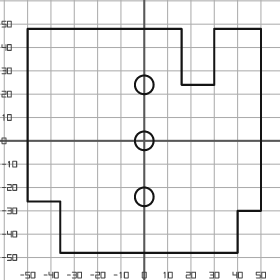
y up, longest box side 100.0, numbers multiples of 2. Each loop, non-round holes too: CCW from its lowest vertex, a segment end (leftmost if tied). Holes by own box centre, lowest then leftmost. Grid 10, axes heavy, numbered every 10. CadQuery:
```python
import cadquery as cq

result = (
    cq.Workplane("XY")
    .moveTo(-36.0, -48.0)
    .lineTo(40.0, -48.0)
    .lineTo(40.0, -30.0)
    .lineTo(50.0, -30.0)
    .lineTo(50.0, 48.0)
    .lineTo(30.0, 48.0)
    .lineTo(30.0, 24.0)
    .lineTo(16.0, 24.0)
    .lineTo(16.0, 48.0)
    .lineTo(-50.0, 48.0)
    .lineTo(-50.0, -26.0)
    .lineTo(-36.0, -26.0)
    .close()
    .moveTo(0.0, -24.0)
    .circle(4.0)
    .moveTo(0.0, 0.0)
    .circle(4.0)
    .moveTo(0.0, 24.0)
    .circle(4.0)
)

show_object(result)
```